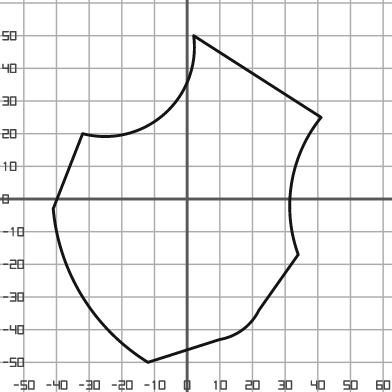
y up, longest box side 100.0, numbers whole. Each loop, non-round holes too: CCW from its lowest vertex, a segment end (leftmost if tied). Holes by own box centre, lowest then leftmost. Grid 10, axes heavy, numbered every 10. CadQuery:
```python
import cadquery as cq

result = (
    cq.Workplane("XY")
    .moveTo(-12.0, -50.0)
    .lineTo(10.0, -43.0)
    .threePointArc((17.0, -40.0), (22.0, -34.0))
    .lineTo(34.0, -17.0)
    .threePointArc((32.0, 5.0), (41.0, 25.0))
    .lineTo(2.0, 50.0)
    .threePointArc((-7.0, 26.0), (-32.0, 20.0))
    .lineTo(-41.0, -3.0)
    .threePointArc((-32.0, -30.0), (-12.0, -50.0))
    .close()
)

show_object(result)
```